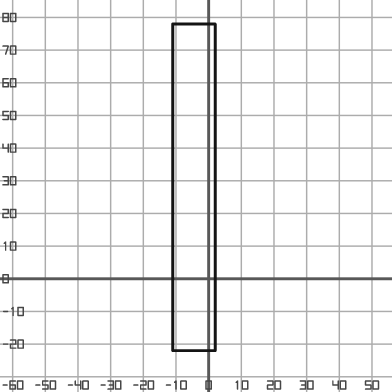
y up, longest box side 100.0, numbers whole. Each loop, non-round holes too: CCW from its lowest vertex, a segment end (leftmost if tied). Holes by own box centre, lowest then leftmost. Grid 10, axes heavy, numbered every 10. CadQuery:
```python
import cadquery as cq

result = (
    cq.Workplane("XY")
    .moveTo(-11.0, -22.0)
    .lineTo(2.0, -22.0)
    .lineTo(2.0, 78.0)
    .lineTo(-11.0, 78.0)
    .close()
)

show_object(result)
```